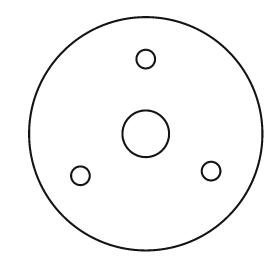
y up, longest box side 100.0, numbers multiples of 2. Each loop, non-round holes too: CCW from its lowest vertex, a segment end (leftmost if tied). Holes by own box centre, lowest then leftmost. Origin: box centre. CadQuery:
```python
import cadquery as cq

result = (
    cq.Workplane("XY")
    .moveTo(0.0, 0.0)
    .circle(50.0)
    .moveTo(-28.0, -18.0)
    .circle(4.0)
    .moveTo(28.0, -16.0)
    .circle(4.0)
    .moveTo(0.0, 0.0)
    .circle(10.0)
    .moveTo(0.0, 32.0)
    .circle(4.0)
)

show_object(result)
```